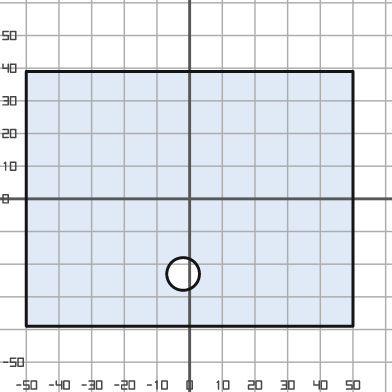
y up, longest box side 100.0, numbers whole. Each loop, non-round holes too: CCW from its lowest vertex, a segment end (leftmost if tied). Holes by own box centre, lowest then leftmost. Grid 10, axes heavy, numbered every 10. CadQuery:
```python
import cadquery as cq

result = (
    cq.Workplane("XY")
    .moveTo(-50.0, -39.0)
    .lineTo(50.0, -39.0)
    .lineTo(50.0, 39.0)
    .lineTo(-50.0, 39.0)
    .close()
    .moveTo(-2.0, -23.0)
    .circle(5.0)
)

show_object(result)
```